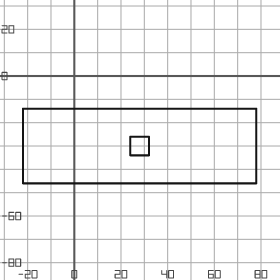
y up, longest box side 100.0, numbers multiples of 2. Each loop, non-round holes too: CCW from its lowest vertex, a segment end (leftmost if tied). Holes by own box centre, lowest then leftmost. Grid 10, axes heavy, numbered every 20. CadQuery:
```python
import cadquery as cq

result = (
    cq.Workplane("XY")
    .moveTo(-22.0, -46.0)
    .lineTo(78.0, -46.0)
    .lineTo(78.0, -14.0)
    .lineTo(-22.0, -14.0)
    .close()
    .moveTo(24.0, -34.0)
    .lineTo(32.0, -34.0)
    .lineTo(32.0, -26.0)
    .lineTo(24.0, -26.0)
    .close()
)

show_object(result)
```